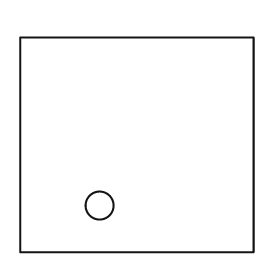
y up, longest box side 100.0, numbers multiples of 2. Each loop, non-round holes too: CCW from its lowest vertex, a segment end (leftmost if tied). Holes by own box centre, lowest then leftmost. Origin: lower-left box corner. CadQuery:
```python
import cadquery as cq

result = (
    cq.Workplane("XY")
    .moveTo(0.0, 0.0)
    .lineTo(100.0, 0.0)
    .lineTo(100.0, 92.0)
    .lineTo(0.0, 92.0)
    .close()
    .moveTo(34.0, 20.0)
    .circle(6.0)
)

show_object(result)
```